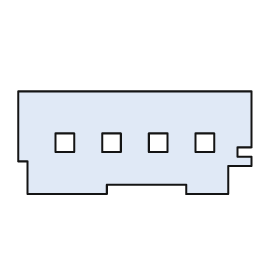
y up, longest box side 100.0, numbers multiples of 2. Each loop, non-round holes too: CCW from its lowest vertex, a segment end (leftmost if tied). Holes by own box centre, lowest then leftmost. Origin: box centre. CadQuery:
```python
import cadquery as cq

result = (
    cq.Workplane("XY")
    .moveTo(-46.0, -22.0)
    .lineTo(-12.0, -22.0)
    .lineTo(-12.0, -18.0)
    .lineTo(22.0, -18.0)
    .lineTo(22.0, -22.0)
    .lineTo(40.0, -22.0)
    .lineTo(40.0, -10.0)
    .lineTo(50.0, -10.0)
    .lineTo(50.0, -6.0)
    .lineTo(44.0, -6.0)
    .lineTo(44.0, -2.0)
    .lineTo(50.0, -2.0)
    .lineTo(50.0, 22.0)
    .lineTo(-50.0, 22.0)
    .lineTo(-50.0, -8.0)
    .lineTo(-46.0, -8.0)
    .close()
    .moveTo(-34.0, -4.0)
    .lineTo(-26.0, -4.0)
    .lineTo(-26.0, 4.0)
    .lineTo(-34.0, 4.0)
    .close()
    .moveTo(-14.0, -4.0)
    .lineTo(-6.0, -4.0)
    .lineTo(-6.0, 4.0)
    .lineTo(-14.0, 4.0)
    .close()
    .moveTo(6.0, -4.0)
    .lineTo(14.0, -4.0)
    .lineTo(14.0, 4.0)
    .lineTo(6.0, 4.0)
    .close()
    .moveTo(26.0, -4.0)
    .lineTo(34.0, -4.0)
    .lineTo(34.0, 4.0)
    .lineTo(26.0, 4.0)
    .close()
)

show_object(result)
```